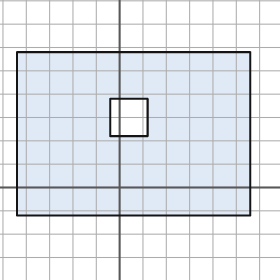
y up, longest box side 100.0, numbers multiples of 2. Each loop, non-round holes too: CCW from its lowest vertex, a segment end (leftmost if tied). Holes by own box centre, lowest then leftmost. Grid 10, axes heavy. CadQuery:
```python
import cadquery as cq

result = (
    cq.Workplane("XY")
    .moveTo(-44.0, -12.0)
    .lineTo(56.0, -12.0)
    .lineTo(56.0, 58.0)
    .lineTo(-44.0, 58.0)
    .close()
    .moveTo(-4.0, 22.0)
    .lineTo(12.0, 22.0)
    .lineTo(12.0, 38.0)
    .lineTo(-4.0, 38.0)
    .close()
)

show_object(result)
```